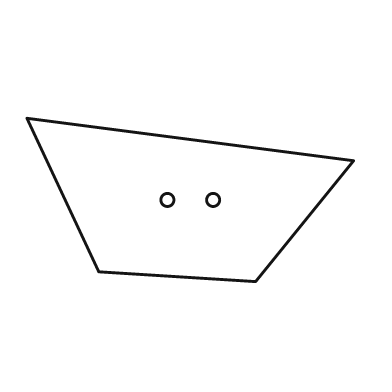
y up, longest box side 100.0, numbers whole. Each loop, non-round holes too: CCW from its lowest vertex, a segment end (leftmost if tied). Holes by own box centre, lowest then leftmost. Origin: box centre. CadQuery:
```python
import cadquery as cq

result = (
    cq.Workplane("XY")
    .moveTo(20.0, -25.0)
    .lineTo(50.0, 12.0)
    .lineTo(-50.0, 25.0)
    .lineTo(-28.0, -22.0)
    .close()
    .moveTo(-7.0, 0.0)
    .circle(2.0)
    .moveTo(7.0, 0.0)
    .circle(2.0)
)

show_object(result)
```